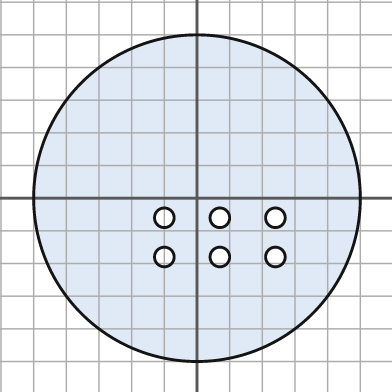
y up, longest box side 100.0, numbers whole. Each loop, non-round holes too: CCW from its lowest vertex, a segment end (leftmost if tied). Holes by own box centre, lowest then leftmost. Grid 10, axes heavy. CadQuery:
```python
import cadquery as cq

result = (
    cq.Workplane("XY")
    .moveTo(0.0, 0.0)
    .circle(50.0)
    .moveTo(-10.0, -18.0)
    .circle(3.0)
    .moveTo(7.0, -18.0)
    .circle(3.0)
    .moveTo(24.0, -18.0)
    .circle(3.0)
    .moveTo(-10.0, -6.0)
    .circle(3.0)
    .moveTo(7.0, -6.0)
    .circle(3.0)
    .moveTo(24.0, -6.0)
    .circle(3.0)
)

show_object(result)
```